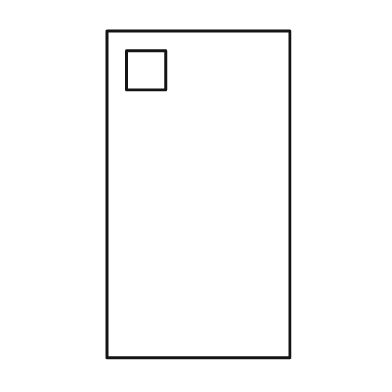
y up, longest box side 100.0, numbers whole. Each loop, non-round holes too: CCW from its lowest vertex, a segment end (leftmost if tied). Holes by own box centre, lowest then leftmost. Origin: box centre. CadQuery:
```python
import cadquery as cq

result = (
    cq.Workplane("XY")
    .moveTo(-28.0, -50.0)
    .lineTo(28.0, -50.0)
    .lineTo(28.0, 50.0)
    .lineTo(-28.0, 50.0)
    .close()
    .moveTo(-22.0, 32.0)
    .lineTo(-10.0, 32.0)
    .lineTo(-10.0, 44.0)
    .lineTo(-22.0, 44.0)
    .close()
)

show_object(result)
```